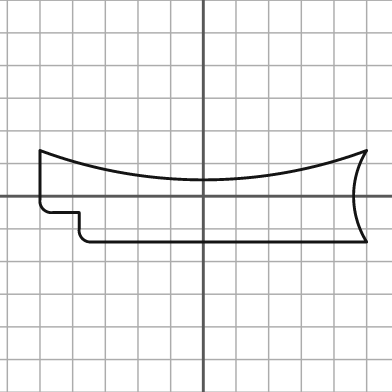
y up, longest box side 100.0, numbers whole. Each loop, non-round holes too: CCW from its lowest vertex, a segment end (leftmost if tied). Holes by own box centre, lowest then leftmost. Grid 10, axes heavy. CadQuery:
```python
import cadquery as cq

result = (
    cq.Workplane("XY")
    .moveTo(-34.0, -14.0)
    .lineTo(50.0, -14.0)
    .threePointArc((46.0, 0.0), (50.0, 14.0))
    .threePointArc((0.0, 5.0), (-50.0, 14.0))
    .lineTo(-50.0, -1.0)
    .threePointArc((-49.0, -4.0), (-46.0, -5.0))
    .lineTo(-38.0, -5.0)
    .lineTo(-38.0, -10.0)
    .threePointArc((-37.0, -13.0), (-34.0, -14.0))
    .close()
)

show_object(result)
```